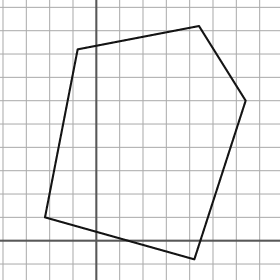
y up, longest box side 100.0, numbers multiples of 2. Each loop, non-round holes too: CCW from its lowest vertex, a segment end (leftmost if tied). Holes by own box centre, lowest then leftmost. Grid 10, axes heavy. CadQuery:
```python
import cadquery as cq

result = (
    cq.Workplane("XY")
    .moveTo(42.0, -8.0)
    .lineTo(64.0, 60.0)
    .lineTo(44.0, 92.0)
    .lineTo(-8.0, 82.0)
    .lineTo(-22.0, 10.0)
    .close()
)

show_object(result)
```